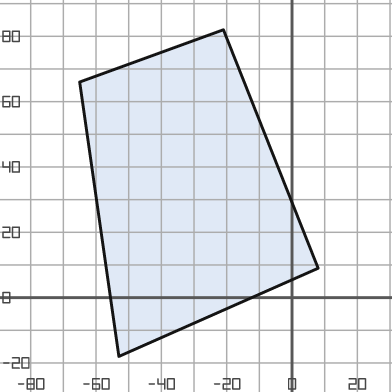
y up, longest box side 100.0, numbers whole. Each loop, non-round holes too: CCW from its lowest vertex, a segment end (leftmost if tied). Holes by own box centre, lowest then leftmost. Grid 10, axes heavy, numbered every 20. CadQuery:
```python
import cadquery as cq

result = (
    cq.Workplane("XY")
    .moveTo(-53.0, -18.0)
    .lineTo(8.0, 9.0)
    .lineTo(-21.0, 82.0)
    .lineTo(-65.0, 66.0)
    .close()
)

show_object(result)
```